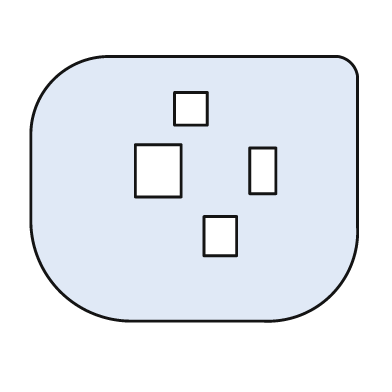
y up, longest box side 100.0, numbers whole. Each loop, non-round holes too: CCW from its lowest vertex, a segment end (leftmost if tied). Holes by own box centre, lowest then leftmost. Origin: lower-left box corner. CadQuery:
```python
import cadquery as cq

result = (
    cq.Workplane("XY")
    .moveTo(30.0, 0.0)
    .lineTo(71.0, 0.0)
    .threePointArc((92.0, 8.0), (100.0, 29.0))
    .lineTo(100.0, 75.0)
    .threePointArc((98.0, 79.0), (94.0, 81.0))
    .lineTo(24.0, 81.0)
    .threePointArc((7.0, 74.0), (0.0, 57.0))
    .lineTo(0.0, 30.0)
    .threePointArc((9.0, 9.0), (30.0, 0.0))
    .close()
    .moveTo(53.0, 20.0)
    .lineTo(63.0, 20.0)
    .lineTo(63.0, 32.0)
    .lineTo(53.0, 32.0)
    .close()
    .moveTo(32.0, 38.0)
    .lineTo(46.0, 38.0)
    .lineTo(46.0, 54.0)
    .lineTo(32.0, 54.0)
    .close()
    .moveTo(67.0, 39.0)
    .lineTo(75.0, 39.0)
    .lineTo(75.0, 53.0)
    .lineTo(67.0, 53.0)
    .close()
    .moveTo(44.0, 60.0)
    .lineTo(54.0, 60.0)
    .lineTo(54.0, 70.0)
    .lineTo(44.0, 70.0)
    .close()
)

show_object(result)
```